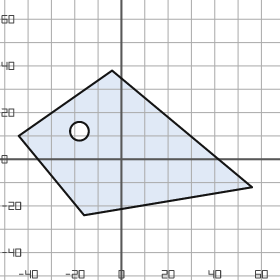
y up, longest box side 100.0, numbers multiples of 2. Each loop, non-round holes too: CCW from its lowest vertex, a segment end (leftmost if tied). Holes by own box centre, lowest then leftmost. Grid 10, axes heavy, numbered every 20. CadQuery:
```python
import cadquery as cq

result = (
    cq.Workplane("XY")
    .moveTo(-16.0, -24.0)
    .lineTo(56.0, -12.0)
    .lineTo(-4.0, 38.0)
    .lineTo(-44.0, 10.0)
    .close()
    .moveTo(-18.0, 12.0)
    .circle(4.0)
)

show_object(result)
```